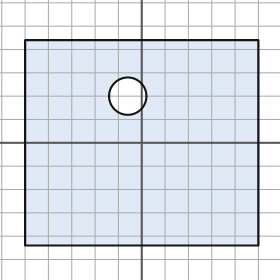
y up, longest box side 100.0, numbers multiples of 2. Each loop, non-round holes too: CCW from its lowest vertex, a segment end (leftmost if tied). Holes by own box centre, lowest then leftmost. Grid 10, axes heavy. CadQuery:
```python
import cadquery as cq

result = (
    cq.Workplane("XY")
    .moveTo(-50.0, -44.0)
    .lineTo(50.0, -44.0)
    .lineTo(50.0, 44.0)
    .lineTo(-50.0, 44.0)
    .close()
    .moveTo(-6.0, 20.0)
    .circle(8.0)
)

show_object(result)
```